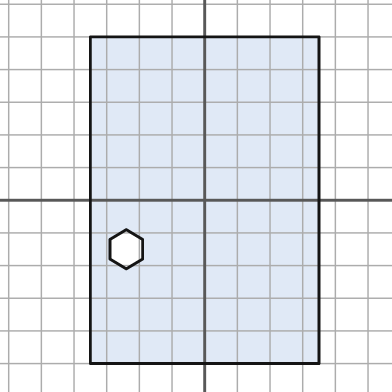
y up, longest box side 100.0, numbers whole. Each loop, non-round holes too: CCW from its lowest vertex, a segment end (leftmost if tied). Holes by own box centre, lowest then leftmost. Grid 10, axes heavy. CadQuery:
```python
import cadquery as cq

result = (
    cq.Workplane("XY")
    .moveTo(-35.0, -50.0)
    .lineTo(35.0, -50.0)
    .lineTo(35.0, 50.0)
    .lineTo(-35.0, 50.0)
    .close()
    .moveTo(-24.0, -21.0)
    .lineTo(-19.0, -18.0)
    .lineTo(-19.0, -12.0)
    .lineTo(-24.0, -9.0)
    .lineTo(-29.0, -12.0)
    .lineTo(-29.0, -18.0)
    .close()
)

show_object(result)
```